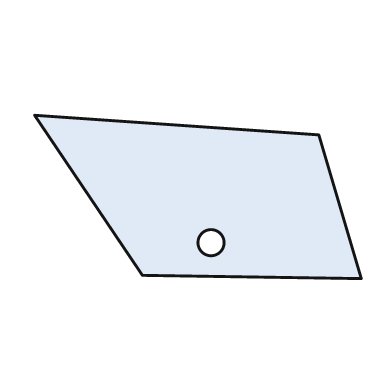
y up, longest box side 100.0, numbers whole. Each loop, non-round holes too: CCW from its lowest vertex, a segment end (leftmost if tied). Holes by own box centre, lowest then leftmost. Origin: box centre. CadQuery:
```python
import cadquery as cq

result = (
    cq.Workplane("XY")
    .moveTo(50.0, -25.0)
    .lineTo(37.0, 19.0)
    .lineTo(-50.0, 25.0)
    .lineTo(-17.0, -24.0)
    .close()
    .moveTo(4.0, -14.0)
    .circle(4.0)
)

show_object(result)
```